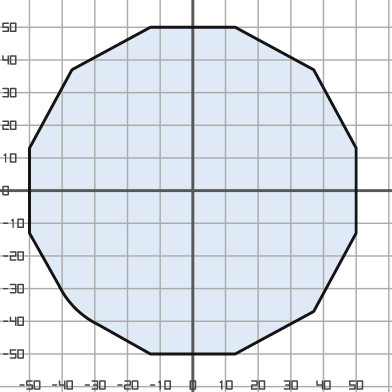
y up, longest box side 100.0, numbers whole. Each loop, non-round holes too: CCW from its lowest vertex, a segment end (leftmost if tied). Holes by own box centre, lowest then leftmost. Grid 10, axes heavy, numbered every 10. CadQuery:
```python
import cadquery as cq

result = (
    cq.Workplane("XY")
    .moveTo(-13.0, -50.0)
    .lineTo(13.0, -50.0)
    .lineTo(37.0, -37.0)
    .lineTo(50.0, -13.0)
    .lineTo(50.0, 13.0)
    .lineTo(37.0, 37.0)
    .lineTo(13.0, 50.0)
    .lineTo(-13.0, 50.0)
    .lineTo(-37.0, 37.0)
    .lineTo(-50.0, 13.0)
    .lineTo(-50.0, -13.0)
    .lineTo(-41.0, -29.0)
    .threePointArc((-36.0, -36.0), (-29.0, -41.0))
    .close()
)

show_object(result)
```